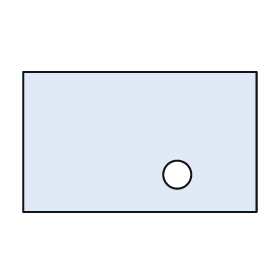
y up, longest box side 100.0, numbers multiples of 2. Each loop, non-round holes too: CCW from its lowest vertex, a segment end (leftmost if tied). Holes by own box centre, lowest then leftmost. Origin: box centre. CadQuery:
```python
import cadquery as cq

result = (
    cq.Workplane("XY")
    .moveTo(-50.0, -30.0)
    .lineTo(50.0, -30.0)
    .lineTo(50.0, 30.0)
    .lineTo(-50.0, 30.0)
    .close()
    .moveTo(16.0, -14.0)
    .circle(6.0)
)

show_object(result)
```